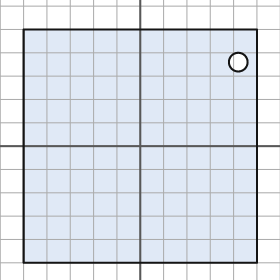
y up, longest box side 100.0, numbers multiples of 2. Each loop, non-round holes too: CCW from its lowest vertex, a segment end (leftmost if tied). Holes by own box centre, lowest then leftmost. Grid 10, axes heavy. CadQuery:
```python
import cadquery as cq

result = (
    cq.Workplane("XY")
    .moveTo(-50.0, -50.0)
    .lineTo(50.0, -50.0)
    .lineTo(50.0, 50.0)
    .lineTo(-50.0, 50.0)
    .close()
    .moveTo(42.0, 36.0)
    .circle(4.0)
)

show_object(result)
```